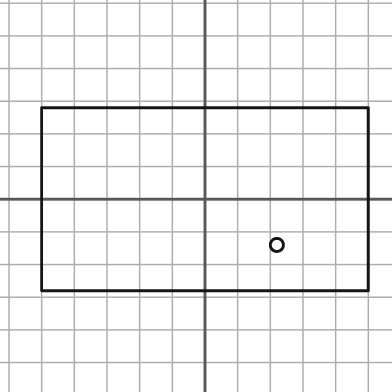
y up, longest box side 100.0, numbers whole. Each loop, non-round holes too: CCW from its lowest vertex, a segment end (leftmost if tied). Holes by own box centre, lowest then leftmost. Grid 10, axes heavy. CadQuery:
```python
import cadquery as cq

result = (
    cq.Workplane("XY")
    .moveTo(-50.0, -28.0)
    .lineTo(50.0, -28.0)
    .lineTo(50.0, 28.0)
    .lineTo(-50.0, 28.0)
    .close()
    .moveTo(22.0, -14.0)
    .circle(2.0)
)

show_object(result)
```